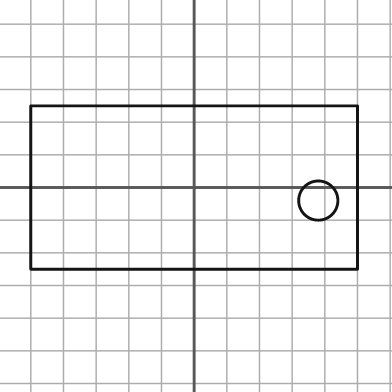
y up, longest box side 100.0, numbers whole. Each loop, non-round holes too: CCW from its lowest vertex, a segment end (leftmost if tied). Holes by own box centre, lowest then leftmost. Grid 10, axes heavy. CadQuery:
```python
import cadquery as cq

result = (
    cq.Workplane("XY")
    .moveTo(-50.0, -25.0)
    .lineTo(50.0, -25.0)
    .lineTo(50.0, 25.0)
    .lineTo(-50.0, 25.0)
    .close()
    .moveTo(38.0, -4.0)
    .circle(6.0)
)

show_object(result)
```